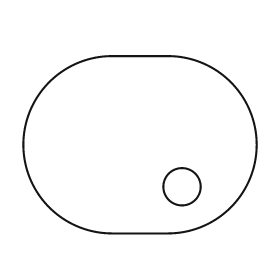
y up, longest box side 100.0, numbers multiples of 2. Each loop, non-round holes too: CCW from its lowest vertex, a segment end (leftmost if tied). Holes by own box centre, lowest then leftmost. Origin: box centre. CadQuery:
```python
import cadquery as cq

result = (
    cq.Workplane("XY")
    .moveTo(-12.0, -38.0)
    .lineTo(12.0, -38.0)
    .threePointArc((50.0, 0.0), (12.0, 38.0))
    .lineTo(-12.0, 38.0)
    .threePointArc((-50.0, 0.0), (-12.0, -38.0))
    .close()
    .moveTo(18.0, -18.0)
    .circle(8.0)
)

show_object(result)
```